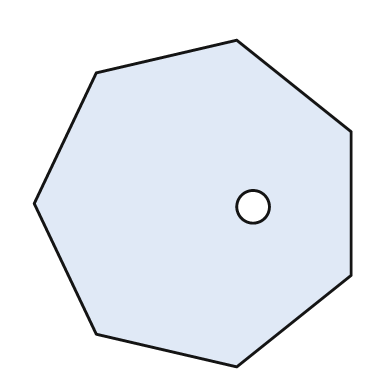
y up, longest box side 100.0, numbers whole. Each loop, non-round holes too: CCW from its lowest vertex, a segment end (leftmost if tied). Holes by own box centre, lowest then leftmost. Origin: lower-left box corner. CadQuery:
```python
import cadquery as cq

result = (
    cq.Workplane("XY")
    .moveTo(62.0, 0.0)
    .lineTo(97.0, 28.0)
    .lineTo(97.0, 72.0)
    .lineTo(62.0, 100.0)
    .lineTo(19.0, 90.0)
    .lineTo(0.0, 50.0)
    .lineTo(19.0, 10.0)
    .close()
    .moveTo(67.0, 49.0)
    .circle(5.0)
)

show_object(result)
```